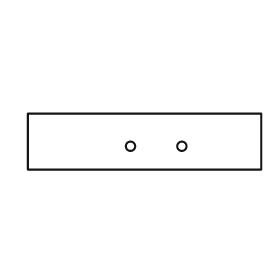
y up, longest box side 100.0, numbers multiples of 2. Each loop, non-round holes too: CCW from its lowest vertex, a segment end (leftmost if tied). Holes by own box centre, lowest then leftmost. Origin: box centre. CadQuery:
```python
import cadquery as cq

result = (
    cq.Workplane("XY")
    .moveTo(-50.0, -12.0)
    .lineTo(50.0, -12.0)
    .lineTo(50.0, 12.0)
    .lineTo(-50.0, 12.0)
    .close()
    .moveTo(-6.0, -2.0)
    .circle(2.0)
    .moveTo(16.0, -2.0)
    .circle(2.0)
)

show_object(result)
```